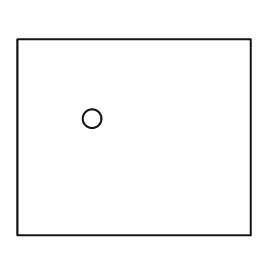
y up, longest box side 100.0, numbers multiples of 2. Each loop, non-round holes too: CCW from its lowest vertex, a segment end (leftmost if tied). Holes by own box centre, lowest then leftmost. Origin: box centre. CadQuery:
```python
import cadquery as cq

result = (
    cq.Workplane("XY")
    .moveTo(-50.0, -42.0)
    .lineTo(50.0, -42.0)
    .lineTo(50.0, 42.0)
    .lineTo(-50.0, 42.0)
    .close()
    .moveTo(-18.0, 8.0)
    .circle(4.0)
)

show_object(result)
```